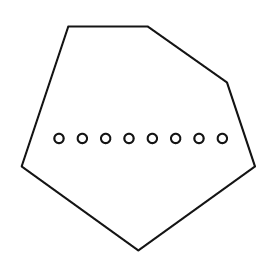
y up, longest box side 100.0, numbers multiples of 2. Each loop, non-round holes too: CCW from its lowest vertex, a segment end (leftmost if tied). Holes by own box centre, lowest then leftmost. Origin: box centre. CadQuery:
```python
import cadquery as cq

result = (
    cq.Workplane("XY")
    .moveTo(0.0, -48.0)
    .lineTo(50.0, -12.0)
    .lineTo(38.0, 24.0)
    .lineTo(4.0, 48.0)
    .lineTo(-30.0, 48.0)
    .lineTo(-50.0, -12.0)
    .close()
    .moveTo(-34.0, 0.0)
    .circle(2.0)
    .moveTo(-24.0, 0.0)
    .circle(2.0)
    .moveTo(-14.0, 0.0)
    .circle(2.0)
    .moveTo(-4.0, 0.0)
    .circle(2.0)
    .moveTo(6.0, 0.0)
    .circle(2.0)
    .moveTo(16.0, 0.0)
    .circle(2.0)
    .moveTo(26.0, 0.0)
    .circle(2.0)
    .moveTo(36.0, 0.0)
    .circle(2.0)
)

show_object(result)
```